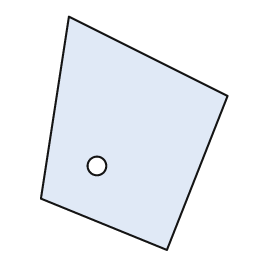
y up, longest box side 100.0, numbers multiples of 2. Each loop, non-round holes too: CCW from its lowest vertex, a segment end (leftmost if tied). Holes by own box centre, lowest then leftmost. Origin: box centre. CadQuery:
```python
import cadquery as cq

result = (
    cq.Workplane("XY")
    .moveTo(14.0, -50.0)
    .lineTo(40.0, 16.0)
    .lineTo(-28.0, 50.0)
    .lineTo(-40.0, -28.0)
    .close()
    .moveTo(-16.0, -14.0)
    .circle(4.0)
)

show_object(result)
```